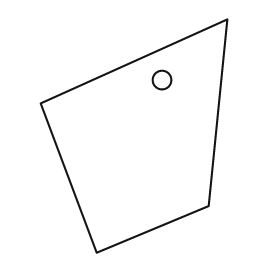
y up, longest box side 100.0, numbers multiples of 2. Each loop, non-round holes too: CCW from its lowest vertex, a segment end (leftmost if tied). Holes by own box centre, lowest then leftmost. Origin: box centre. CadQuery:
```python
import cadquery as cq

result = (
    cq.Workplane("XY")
    .moveTo(-16.0, -50.0)
    .lineTo(32.0, -30.0)
    .lineTo(40.0, 50.0)
    .lineTo(-40.0, 14.0)
    .close()
    .moveTo(12.0, 24.0)
    .circle(4.0)
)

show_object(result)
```